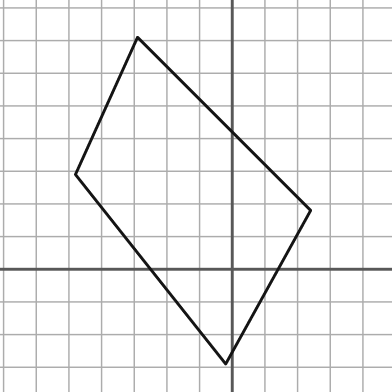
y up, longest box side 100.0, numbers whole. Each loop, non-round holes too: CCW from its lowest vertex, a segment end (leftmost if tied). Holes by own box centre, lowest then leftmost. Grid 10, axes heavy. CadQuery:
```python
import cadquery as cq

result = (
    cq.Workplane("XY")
    .moveTo(-2.0, -29.0)
    .lineTo(24.0, 18.0)
    .lineTo(-29.0, 71.0)
    .lineTo(-48.0, 29.0)
    .close()
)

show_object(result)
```